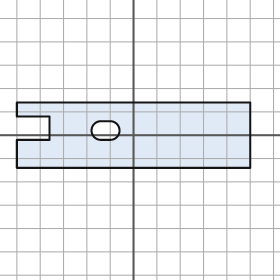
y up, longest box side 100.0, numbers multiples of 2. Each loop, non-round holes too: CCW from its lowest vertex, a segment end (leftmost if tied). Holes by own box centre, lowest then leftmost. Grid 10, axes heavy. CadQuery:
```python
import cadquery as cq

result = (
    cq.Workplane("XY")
    .moveTo(-50.0, -14.0)
    .lineTo(50.0, -14.0)
    .lineTo(50.0, 14.0)
    .lineTo(-50.0, 14.0)
    .lineTo(-50.0, 8.0)
    .lineTo(-36.0, 8.0)
    .lineTo(-36.0, -2.0)
    .lineTo(-50.0, -2.0)
    .close()
    .moveTo(-14.0, -2.0)
    .lineTo(-10.0, -2.0)
    .threePointArc((-6.0, 2.0), (-10.0, 6.0))
    .lineTo(-14.0, 6.0)
    .threePointArc((-18.0, 2.0), (-14.0, -2.0))
    .close()
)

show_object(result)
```